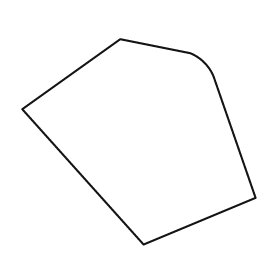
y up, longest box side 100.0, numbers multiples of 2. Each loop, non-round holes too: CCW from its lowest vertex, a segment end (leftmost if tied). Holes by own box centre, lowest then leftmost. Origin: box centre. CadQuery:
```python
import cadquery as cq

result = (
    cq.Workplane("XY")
    .moveTo(2.0, -44.0)
    .lineTo(50.0, -24.0)
    .lineTo(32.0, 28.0)
    .threePointArc((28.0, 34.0), (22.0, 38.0))
    .lineTo(-8.0, 44.0)
    .lineTo(-50.0, 14.0)
    .close()
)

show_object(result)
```